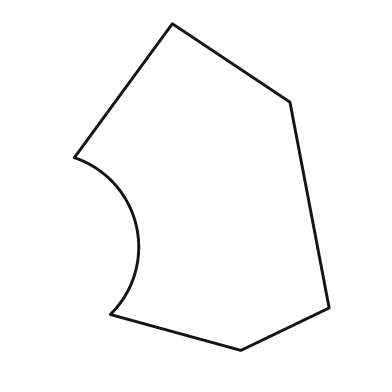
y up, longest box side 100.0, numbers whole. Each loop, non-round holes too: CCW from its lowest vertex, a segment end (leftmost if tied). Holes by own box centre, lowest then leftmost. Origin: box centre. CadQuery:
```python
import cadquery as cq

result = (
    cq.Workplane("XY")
    .moveTo(12.0, -50.0)
    .lineTo(39.0, -37.0)
    .lineTo(27.0, 26.0)
    .lineTo(-9.0, 50.0)
    .lineTo(-39.0, 9.0)
    .threePointArc((-20.0, -12.0), (-28.0, -39.0))
    .close()
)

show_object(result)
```